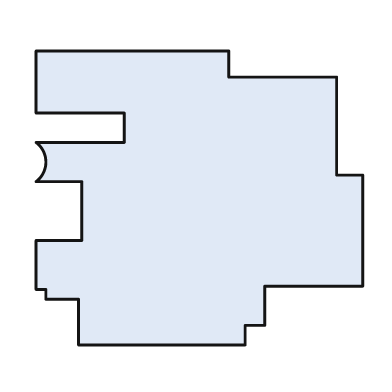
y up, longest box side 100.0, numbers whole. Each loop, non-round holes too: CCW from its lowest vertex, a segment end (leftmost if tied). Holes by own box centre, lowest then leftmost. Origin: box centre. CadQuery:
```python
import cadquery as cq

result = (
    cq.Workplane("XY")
    .moveTo(-37.0, -45.0)
    .lineTo(14.0, -45.0)
    .lineTo(14.0, -39.0)
    .lineTo(20.0, -39.0)
    .lineTo(20.0, -27.0)
    .lineTo(50.0, -27.0)
    .lineTo(50.0, 7.0)
    .lineTo(42.0, 7.0)
    .lineTo(42.0, 37.0)
    .lineTo(9.0, 37.0)
    .lineTo(9.0, 45.0)
    .lineTo(-50.0, 45.0)
    .lineTo(-50.0, 26.0)
    .lineTo(-23.0, 26.0)
    .lineTo(-23.0, 17.0)
    .lineTo(-50.0, 17.0)
    .threePointArc((-47.0, 11.0), (-50.0, 5.0))
    .lineTo(-36.0, 5.0)
    .lineTo(-36.0, -13.0)
    .lineTo(-50.0, -13.0)
    .lineTo(-50.0, -28.0)
    .lineTo(-47.0, -28.0)
    .lineTo(-47.0, -31.0)
    .lineTo(-37.0, -31.0)
    .close()
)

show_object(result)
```